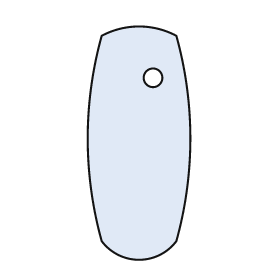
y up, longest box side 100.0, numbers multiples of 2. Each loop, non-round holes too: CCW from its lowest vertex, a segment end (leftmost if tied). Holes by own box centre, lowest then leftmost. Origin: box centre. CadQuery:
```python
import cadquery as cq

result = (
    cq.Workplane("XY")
    .moveTo(-16.0, -42.0)
    .threePointArc((0.0, -50.0), (16.0, -42.0))
    .threePointArc((22.0, 2.0), (16.0, 46.0))
    .threePointArc((0.0, 50.0), (-16.0, 46.0))
    .threePointArc((-22.0, 2.0), (-16.0, -42.0))
    .close()
    .moveTo(6.0, 28.0)
    .circle(4.0)
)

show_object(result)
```